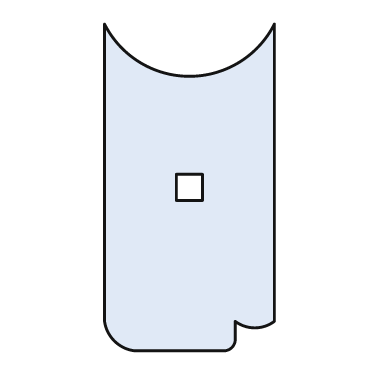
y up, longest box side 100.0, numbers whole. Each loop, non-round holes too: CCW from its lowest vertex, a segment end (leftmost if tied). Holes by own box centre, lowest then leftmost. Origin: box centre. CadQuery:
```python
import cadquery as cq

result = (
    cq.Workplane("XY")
    .moveTo(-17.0, -50.0)
    .lineTo(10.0, -50.0)
    .threePointArc((13.0, -49.0), (14.0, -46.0))
    .lineTo(14.0, -41.0)
    .threePointArc((20.0, -43.0), (26.0, -41.0))
    .lineTo(26.0, 50.0)
    .threePointArc((0.0, 34.0), (-26.0, 50.0))
    .lineTo(-26.0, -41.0)
    .threePointArc((-23.0, -47.0), (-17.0, -50.0))
    .close()
    .moveTo(-4.0, -4.0)
    .lineTo(4.0, -4.0)
    .lineTo(4.0, 4.0)
    .lineTo(-4.0, 4.0)
    .close()
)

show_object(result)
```